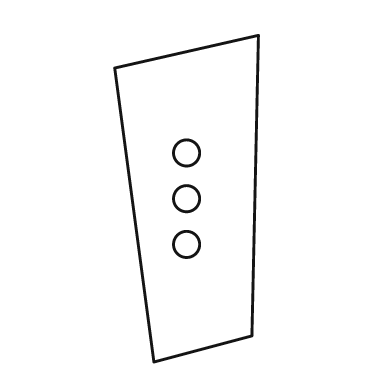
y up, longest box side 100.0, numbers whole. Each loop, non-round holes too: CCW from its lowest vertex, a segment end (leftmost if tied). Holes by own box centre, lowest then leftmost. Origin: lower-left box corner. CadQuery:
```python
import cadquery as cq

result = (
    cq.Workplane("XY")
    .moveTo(12.0, 0.0)
    .lineTo(42.0, 8.0)
    .lineTo(44.0, 100.0)
    .lineTo(0.0, 90.0)
    .close()
    .moveTo(22.0, 36.0)
    .circle(4.0)
    .moveTo(22.0, 50.0)
    .circle(4.0)
    .moveTo(22.0, 64.0)
    .circle(4.0)
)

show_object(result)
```